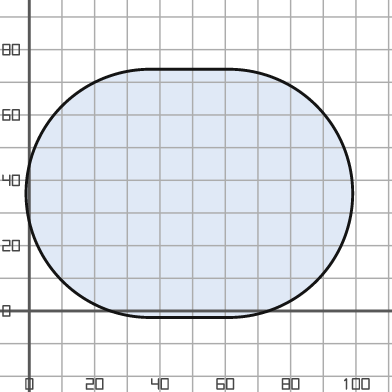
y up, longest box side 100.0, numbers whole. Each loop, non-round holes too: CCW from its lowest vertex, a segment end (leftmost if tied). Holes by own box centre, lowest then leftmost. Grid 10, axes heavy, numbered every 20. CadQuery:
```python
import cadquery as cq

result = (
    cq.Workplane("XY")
    .moveTo(37.0, -2.0)
    .lineTo(61.0, -2.0)
    .threePointArc((99.0, 36.0), (61.0, 74.0))
    .lineTo(37.0, 74.0)
    .threePointArc((-1.0, 36.0), (37.0, -2.0))
    .close()
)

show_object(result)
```